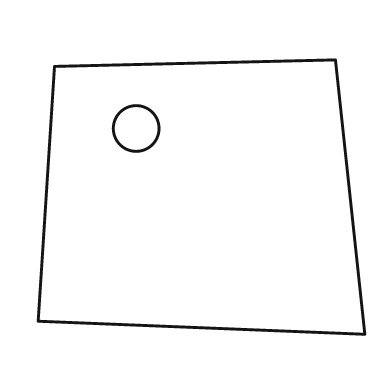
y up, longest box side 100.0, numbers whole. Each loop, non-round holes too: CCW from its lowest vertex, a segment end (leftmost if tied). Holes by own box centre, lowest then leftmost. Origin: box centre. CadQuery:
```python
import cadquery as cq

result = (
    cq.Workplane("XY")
    .moveTo(50.0, -42.0)
    .lineTo(41.0, 42.0)
    .lineTo(-45.0, 40.0)
    .lineTo(-50.0, -38.0)
    .close()
    .moveTo(-20.0, 21.0)
    .circle(7.0)
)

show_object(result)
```